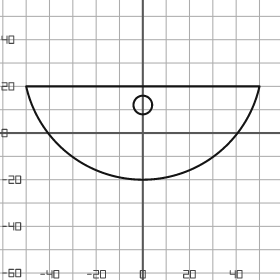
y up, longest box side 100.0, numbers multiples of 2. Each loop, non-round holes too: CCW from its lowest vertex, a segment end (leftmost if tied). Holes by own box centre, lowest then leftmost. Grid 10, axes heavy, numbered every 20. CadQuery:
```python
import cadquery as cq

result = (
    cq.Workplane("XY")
    .moveTo(-50.0, 20.0)
    .threePointArc((0.0, -20.0), (50.0, 20.0))
    .close()
    .moveTo(0.0, 12.0)
    .circle(4.0)
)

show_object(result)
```